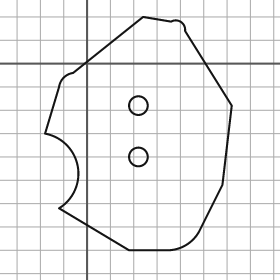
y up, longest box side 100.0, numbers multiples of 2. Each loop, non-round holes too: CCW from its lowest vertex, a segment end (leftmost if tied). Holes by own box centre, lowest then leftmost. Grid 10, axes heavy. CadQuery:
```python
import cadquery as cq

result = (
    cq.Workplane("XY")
    .moveTo(18.0, -80.0)
    .lineTo(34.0, -80.0)
    .threePointArc((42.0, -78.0), (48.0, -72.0))
    .lineTo(58.0, -52.0)
    .lineTo(62.0, -18.0)
    .lineTo(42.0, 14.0)
    .threePointArc((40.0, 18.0), (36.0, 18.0))
    .lineTo(24.0, 20.0)
    .lineTo(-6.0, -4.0)
    .threePointArc((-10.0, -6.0), (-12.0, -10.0))
    .lineTo(-18.0, -30.0)
    .threePointArc((-4.0, -44.0), (-12.0, -62.0))
    .close()
    .moveTo(22.0, -40.0)
    .circle(4.0)
    .moveTo(22.0, -18.0)
    .circle(4.0)
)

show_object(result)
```